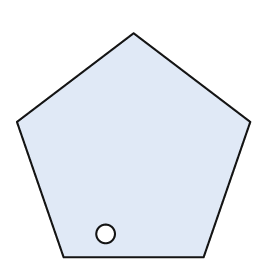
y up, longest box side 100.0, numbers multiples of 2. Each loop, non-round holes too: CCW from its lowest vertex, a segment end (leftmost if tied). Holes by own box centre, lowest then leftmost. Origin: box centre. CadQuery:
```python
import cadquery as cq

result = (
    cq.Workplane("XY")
    .moveTo(-30.0, -48.0)
    .lineTo(30.0, -48.0)
    .lineTo(50.0, 10.0)
    .lineTo(0.0, 48.0)
    .lineTo(-50.0, 10.0)
    .close()
    .moveTo(-12.0, -38.0)
    .circle(4.0)
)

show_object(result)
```